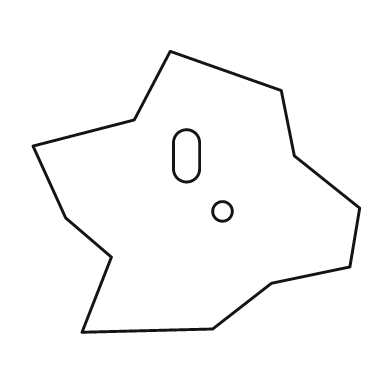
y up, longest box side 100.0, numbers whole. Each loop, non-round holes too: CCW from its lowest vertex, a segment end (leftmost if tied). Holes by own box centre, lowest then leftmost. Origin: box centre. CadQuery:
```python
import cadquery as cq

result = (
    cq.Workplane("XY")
    .moveTo(-35.0, -43.0)
    .lineTo(5.0, -42.0)
    .lineTo(23.0, -28.0)
    .lineTo(47.0, -23.0)
    .lineTo(50.0, -5.0)
    .lineTo(30.0, 11.0)
    .lineTo(26.0, 31.0)
    .lineTo(-8.0, 43.0)
    .lineTo(-19.0, 22.0)
    .lineTo(-50.0, 14.0)
    .lineTo(-40.0, -8.0)
    .lineTo(-26.0, -20.0)
    .close()
    .moveTo(8.0, -6.0)
    .circle(3.0)
    .moveTo(-7.0, 7.0)
    .threePointArc((-3.0, 3.0), (1.0, 7.0))
    .lineTo(1.0, 15.0)
    .threePointArc((-3.0, 19.0), (-7.0, 15.0))
    .close()
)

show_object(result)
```